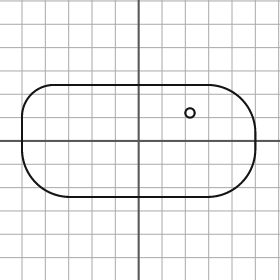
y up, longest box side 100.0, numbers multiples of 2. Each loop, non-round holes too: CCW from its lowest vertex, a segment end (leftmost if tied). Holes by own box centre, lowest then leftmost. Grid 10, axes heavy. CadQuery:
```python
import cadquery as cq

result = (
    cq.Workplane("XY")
    .moveTo(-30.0, -24.0)
    .lineTo(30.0, -24.0)
    .threePointArc((44.0, -18.0), (50.0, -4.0))
    .lineTo(50.0, 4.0)
    .threePointArc((44.0, 18.0), (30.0, 24.0))
    .lineTo(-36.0, 24.0)
    .threePointArc((-46.0, 20.0), (-50.0, 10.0))
    .lineTo(-50.0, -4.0)
    .threePointArc((-44.0, -18.0), (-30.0, -24.0))
    .close()
    .moveTo(22.0, 12.0)
    .circle(2.0)
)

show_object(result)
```